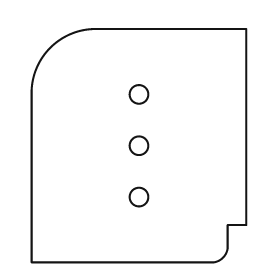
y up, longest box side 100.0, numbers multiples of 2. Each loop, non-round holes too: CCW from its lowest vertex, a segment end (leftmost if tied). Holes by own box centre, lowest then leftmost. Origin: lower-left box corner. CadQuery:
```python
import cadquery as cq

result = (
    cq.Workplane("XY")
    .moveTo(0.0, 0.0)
    .lineTo(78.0, 0.0)
    .threePointArc((82.0, 2.0), (84.0, 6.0))
    .lineTo(84.0, 16.0)
    .lineTo(92.0, 16.0)
    .lineTo(92.0, 100.0)
    .lineTo(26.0, 100.0)
    .threePointArc((8.0, 92.0), (0.0, 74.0))
    .close()
    .moveTo(46.0, 28.0)
    .circle(4.0)
    .moveTo(46.0, 50.0)
    .circle(4.0)
    .moveTo(46.0, 72.0)
    .circle(4.0)
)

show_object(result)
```